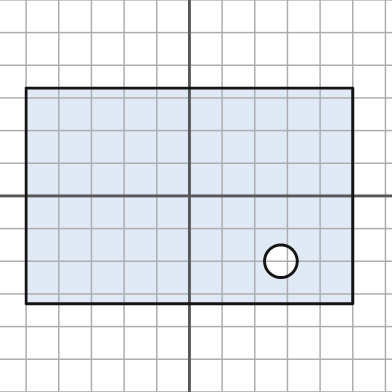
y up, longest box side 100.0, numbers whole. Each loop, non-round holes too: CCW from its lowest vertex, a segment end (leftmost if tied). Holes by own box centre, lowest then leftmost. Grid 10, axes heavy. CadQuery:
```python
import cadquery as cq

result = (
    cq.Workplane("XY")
    .moveTo(-50.0, -33.0)
    .lineTo(50.0, -33.0)
    .lineTo(50.0, 33.0)
    .lineTo(-50.0, 33.0)
    .close()
    .moveTo(28.0, -20.0)
    .circle(5.0)
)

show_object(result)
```